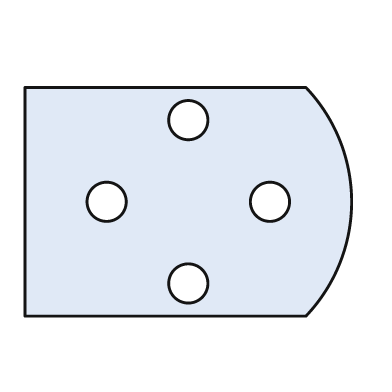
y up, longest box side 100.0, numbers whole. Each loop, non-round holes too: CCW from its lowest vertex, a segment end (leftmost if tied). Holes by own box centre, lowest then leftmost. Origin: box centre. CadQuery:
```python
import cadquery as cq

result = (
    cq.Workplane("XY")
    .moveTo(-50.0, -35.0)
    .lineTo(36.0, -35.0)
    .threePointArc((50.0, 0.0), (36.0, 35.0))
    .lineTo(-50.0, 35.0)
    .close()
    .moveTo(0.0, -25.0)
    .circle(6.0)
    .moveTo(-25.0, 0.0)
    .circle(6.0)
    .moveTo(25.0, 0.0)
    .circle(6.0)
    .moveTo(0.0, 25.0)
    .circle(6.0)
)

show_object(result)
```